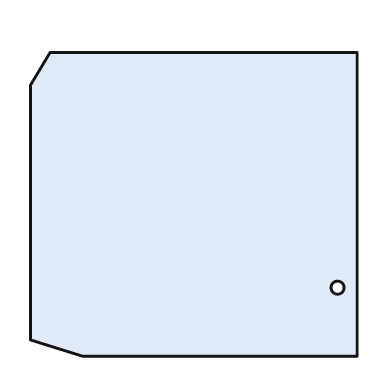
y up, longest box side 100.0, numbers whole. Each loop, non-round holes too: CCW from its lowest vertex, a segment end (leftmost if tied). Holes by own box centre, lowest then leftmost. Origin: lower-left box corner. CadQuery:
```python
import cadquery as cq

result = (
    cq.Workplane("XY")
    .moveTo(16.0, 0.0)
    .lineTo(100.0, 0.0)
    .lineTo(100.0, 93.0)
    .lineTo(6.0, 93.0)
    .lineTo(0.0, 83.0)
    .lineTo(0.0, 5.0)
    .close()
    .moveTo(94.0, 21.0)
    .circle(2.0)
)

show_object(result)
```